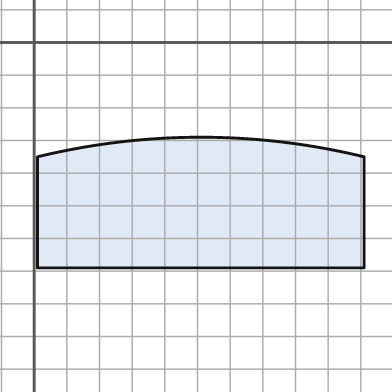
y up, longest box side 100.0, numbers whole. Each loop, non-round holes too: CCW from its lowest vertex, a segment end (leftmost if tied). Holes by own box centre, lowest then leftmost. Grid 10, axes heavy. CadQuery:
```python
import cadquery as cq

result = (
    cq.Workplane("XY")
    .moveTo(1.0, -69.0)
    .lineTo(101.0, -69.0)
    .lineTo(101.0, -35.0)
    .threePointArc((51.0, -29.0), (1.0, -35.0))
    .close()
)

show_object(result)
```